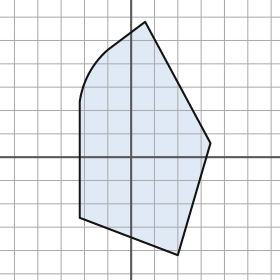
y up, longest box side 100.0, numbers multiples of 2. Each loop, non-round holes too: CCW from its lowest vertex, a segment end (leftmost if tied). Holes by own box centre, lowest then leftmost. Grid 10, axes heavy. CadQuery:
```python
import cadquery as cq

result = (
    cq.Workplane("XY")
    .moveTo(20.0, -42.0)
    .lineTo(34.0, 6.0)
    .lineTo(6.0, 58.0)
    .lineTo(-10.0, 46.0)
    .threePointArc((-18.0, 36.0), (-22.0, 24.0))
    .lineTo(-22.0, -26.0)
    .close()
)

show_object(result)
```